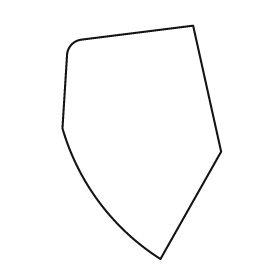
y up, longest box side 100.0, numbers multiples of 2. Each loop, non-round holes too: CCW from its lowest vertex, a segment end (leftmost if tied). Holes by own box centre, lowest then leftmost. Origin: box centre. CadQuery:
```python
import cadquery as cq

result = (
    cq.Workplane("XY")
    .moveTo(8.0, -50.0)
    .lineTo(34.0, -4.0)
    .lineTo(22.0, 50.0)
    .lineTo(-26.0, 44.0)
    .threePointArc((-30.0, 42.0), (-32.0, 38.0))
    .lineTo(-34.0, 6.0)
    .threePointArc((-18.0, -26.0), (8.0, -50.0))
    .close()
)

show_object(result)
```